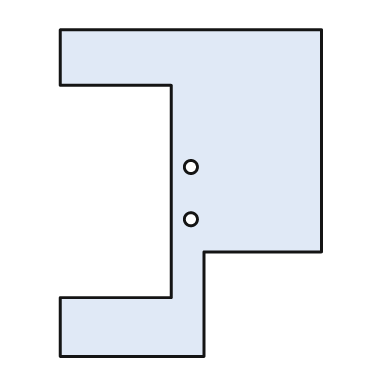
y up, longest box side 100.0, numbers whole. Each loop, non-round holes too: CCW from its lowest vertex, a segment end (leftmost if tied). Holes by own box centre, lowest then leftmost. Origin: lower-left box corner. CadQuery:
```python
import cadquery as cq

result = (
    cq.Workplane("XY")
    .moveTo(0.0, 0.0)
    .lineTo(44.0, 0.0)
    .lineTo(44.0, 32.0)
    .lineTo(80.0, 32.0)
    .lineTo(80.0, 100.0)
    .lineTo(0.0, 100.0)
    .lineTo(0.0, 83.0)
    .lineTo(34.0, 83.0)
    .lineTo(34.0, 18.0)
    .lineTo(0.0, 18.0)
    .close()
    .moveTo(40.0, 42.0)
    .circle(2.0)
    .moveTo(40.0, 58.0)
    .circle(2.0)
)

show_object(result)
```